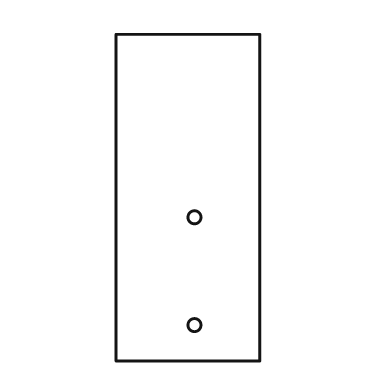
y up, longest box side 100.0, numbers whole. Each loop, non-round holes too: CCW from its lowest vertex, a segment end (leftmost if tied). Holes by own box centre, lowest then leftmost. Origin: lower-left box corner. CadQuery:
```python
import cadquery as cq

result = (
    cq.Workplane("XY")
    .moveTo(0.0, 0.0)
    .lineTo(44.0, 0.0)
    .lineTo(44.0, 100.0)
    .lineTo(0.0, 100.0)
    .close()
    .moveTo(24.0, 11.0)
    .circle(2.0)
    .moveTo(24.0, 44.0)
    .circle(2.0)
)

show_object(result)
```